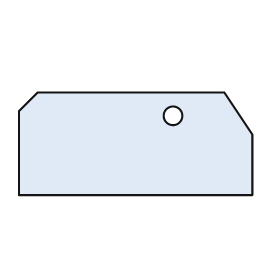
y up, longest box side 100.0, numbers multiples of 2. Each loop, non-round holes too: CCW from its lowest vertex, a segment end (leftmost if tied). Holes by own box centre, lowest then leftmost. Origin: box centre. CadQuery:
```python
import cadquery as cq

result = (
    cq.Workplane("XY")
    .moveTo(-50.0, -22.0)
    .lineTo(50.0, -22.0)
    .lineTo(50.0, 4.0)
    .lineTo(38.0, 22.0)
    .lineTo(-42.0, 22.0)
    .lineTo(-50.0, 14.0)
    .close()
    .moveTo(16.0, 12.0)
    .circle(4.0)
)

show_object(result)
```